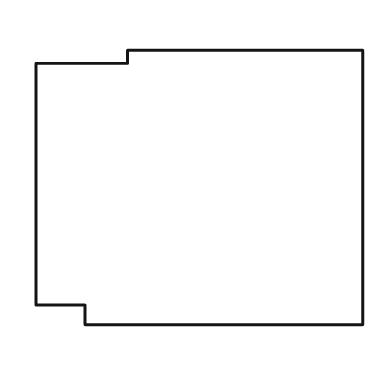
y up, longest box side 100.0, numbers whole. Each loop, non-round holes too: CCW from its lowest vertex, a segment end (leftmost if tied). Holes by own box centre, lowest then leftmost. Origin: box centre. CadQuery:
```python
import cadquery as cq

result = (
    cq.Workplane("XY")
    .moveTo(-35.0, -42.0)
    .lineTo(50.0, -42.0)
    .lineTo(50.0, 42.0)
    .lineTo(-22.0, 42.0)
    .lineTo(-22.0, 38.0)
    .lineTo(-50.0, 38.0)
    .lineTo(-50.0, -36.0)
    .lineTo(-35.0, -36.0)
    .close()
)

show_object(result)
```